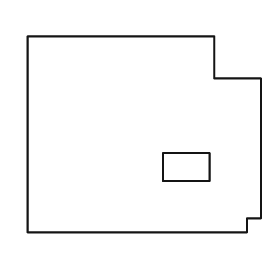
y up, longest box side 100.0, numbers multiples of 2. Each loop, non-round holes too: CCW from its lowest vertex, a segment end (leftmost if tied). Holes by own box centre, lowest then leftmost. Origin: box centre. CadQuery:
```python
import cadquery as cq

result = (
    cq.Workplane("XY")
    .moveTo(-50.0, -42.0)
    .lineTo(44.0, -42.0)
    .lineTo(44.0, -36.0)
    .lineTo(50.0, -36.0)
    .lineTo(50.0, 24.0)
    .lineTo(30.0, 24.0)
    .lineTo(30.0, 42.0)
    .lineTo(-50.0, 42.0)
    .close()
    .moveTo(8.0, -20.0)
    .lineTo(28.0, -20.0)
    .lineTo(28.0, -8.0)
    .lineTo(8.0, -8.0)
    .close()
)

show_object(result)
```